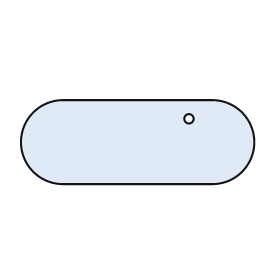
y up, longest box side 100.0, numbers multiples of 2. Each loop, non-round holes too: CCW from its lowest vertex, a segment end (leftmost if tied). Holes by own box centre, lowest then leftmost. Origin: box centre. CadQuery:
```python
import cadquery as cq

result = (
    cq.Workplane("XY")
    .moveTo(-32.0, -18.0)
    .lineTo(32.0, -18.0)
    .threePointArc((50.0, 0.0), (32.0, 18.0))
    .lineTo(-32.0, 18.0)
    .threePointArc((-50.0, 0.0), (-32.0, -18.0))
    .close()
    .moveTo(22.0, 10.0)
    .circle(2.0)
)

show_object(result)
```